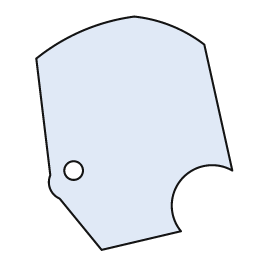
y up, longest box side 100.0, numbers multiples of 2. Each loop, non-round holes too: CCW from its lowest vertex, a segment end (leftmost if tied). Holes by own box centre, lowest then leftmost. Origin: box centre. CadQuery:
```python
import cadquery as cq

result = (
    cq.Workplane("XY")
    .moveTo(-14.0, -50.0)
    .lineTo(20.0, -42.0)
    .threePointArc((20.0, -20.0), (42.0, -16.0))
    .lineTo(30.0, 38.0)
    .threePointArc((16.0, 46.0), (0.0, 50.0))
    .threePointArc((-22.0, 44.0), (-42.0, 32.0))
    .lineTo(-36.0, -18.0)
    .threePointArc((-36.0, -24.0), (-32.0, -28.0))
    .close()
    .moveTo(-26.0, -16.0)
    .circle(4.0)
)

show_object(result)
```